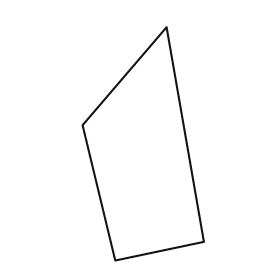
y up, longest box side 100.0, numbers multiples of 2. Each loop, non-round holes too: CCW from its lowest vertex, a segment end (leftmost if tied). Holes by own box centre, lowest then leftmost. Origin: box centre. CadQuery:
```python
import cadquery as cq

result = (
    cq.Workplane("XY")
    .moveTo(-12.0, -50.0)
    .lineTo(26.0, -42.0)
    .lineTo(10.0, 50.0)
    .lineTo(-26.0, 8.0)
    .close()
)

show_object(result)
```